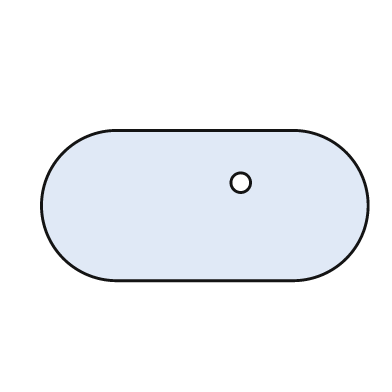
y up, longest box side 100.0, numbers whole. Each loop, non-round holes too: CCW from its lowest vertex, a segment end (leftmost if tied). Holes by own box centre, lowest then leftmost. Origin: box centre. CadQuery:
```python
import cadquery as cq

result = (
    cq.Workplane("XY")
    .moveTo(-27.0, -23.0)
    .lineTo(27.0, -23.0)
    .threePointArc((50.0, 0.0), (27.0, 23.0))
    .lineTo(-27.0, 23.0)
    .threePointArc((-50.0, 0.0), (-27.0, -23.0))
    .close()
    .moveTo(11.0, 7.0)
    .circle(3.0)
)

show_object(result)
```